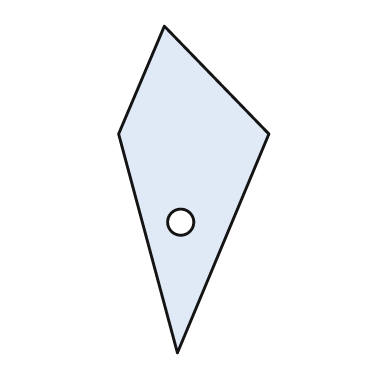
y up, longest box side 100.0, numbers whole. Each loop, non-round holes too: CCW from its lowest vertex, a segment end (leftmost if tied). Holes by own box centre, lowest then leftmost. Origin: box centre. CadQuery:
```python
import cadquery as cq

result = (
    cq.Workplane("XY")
    .moveTo(-5.0, -50.0)
    .lineTo(23.0, 17.0)
    .lineTo(-9.0, 50.0)
    .lineTo(-23.0, 17.0)
    .close()
    .moveTo(-4.0, -10.0)
    .circle(4.0)
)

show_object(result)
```